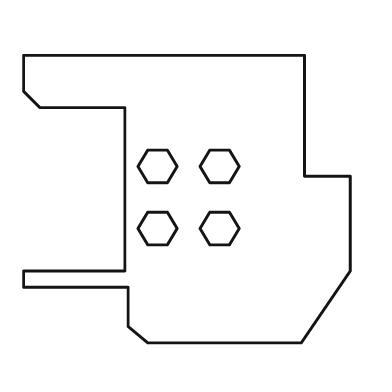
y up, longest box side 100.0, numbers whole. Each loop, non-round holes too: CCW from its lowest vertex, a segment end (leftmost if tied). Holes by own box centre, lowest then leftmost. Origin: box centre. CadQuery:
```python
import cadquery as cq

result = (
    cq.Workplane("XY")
    .moveTo(-12.0, -44.0)
    .lineTo(35.0, -44.0)
    .lineTo(50.0, -22.0)
    .lineTo(50.0, 7.0)
    .lineTo(36.0, 7.0)
    .lineTo(36.0, 44.0)
    .lineTo(-50.0, 44.0)
    .lineTo(-50.0, 33.0)
    .lineTo(-45.0, 28.0)
    .lineTo(-19.0, 28.0)
    .lineTo(-19.0, -22.0)
    .lineTo(-50.0, -22.0)
    .lineTo(-50.0, -27.0)
    .lineTo(-18.0, -27.0)
    .lineTo(-18.0, -39.0)
    .close()
    .moveTo(-12.0, -14.0)
    .lineTo(-6.0, -14.0)
    .lineTo(-3.0, -9.0)
    .lineTo(-6.0, -4.0)
    .lineTo(-12.0, -4.0)
    .lineTo(-15.0, -9.0)
    .close()
    .moveTo(7.0, -14.0)
    .lineTo(13.0, -14.0)
    .lineTo(16.0, -9.0)
    .lineTo(13.0, -4.0)
    .lineTo(7.0, -4.0)
    .lineTo(4.0, -9.0)
    .close()
    .moveTo(-12.0, 5.0)
    .lineTo(-6.0, 5.0)
    .lineTo(-3.0, 10.0)
    .lineTo(-6.0, 15.0)
    .lineTo(-12.0, 15.0)
    .lineTo(-15.0, 10.0)
    .close()
    .moveTo(7.0, 5.0)
    .lineTo(13.0, 5.0)
    .lineTo(16.0, 10.0)
    .lineTo(13.0, 15.0)
    .lineTo(7.0, 15.0)
    .lineTo(4.0, 10.0)
    .close()
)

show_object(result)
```